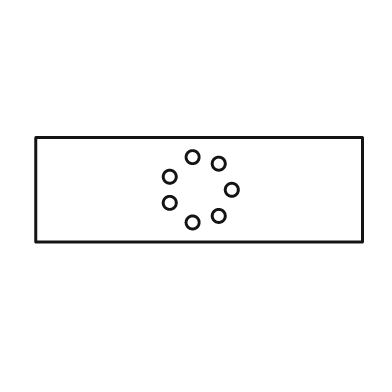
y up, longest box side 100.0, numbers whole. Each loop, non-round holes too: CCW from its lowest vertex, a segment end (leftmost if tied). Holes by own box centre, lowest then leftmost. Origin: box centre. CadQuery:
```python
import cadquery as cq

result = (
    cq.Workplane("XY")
    .moveTo(-50.0, -16.0)
    .lineTo(50.0, -16.0)
    .lineTo(50.0, 16.0)
    .lineTo(-50.0, 16.0)
    .close()
    .moveTo(-2.0, -10.0)
    .circle(2.0)
    .moveTo(6.0, -8.0)
    .circle(2.0)
    .moveTo(-9.0, -4.0)
    .circle(2.0)
    .moveTo(10.0, 0.0)
    .circle(2.0)
    .moveTo(-9.0, 4.0)
    .circle(2.0)
    .moveTo(6.0, 8.0)
    .circle(2.0)
    .moveTo(-2.0, 10.0)
    .circle(2.0)
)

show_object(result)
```